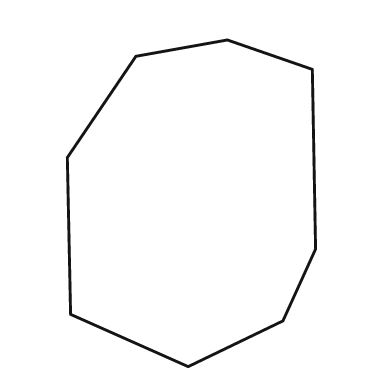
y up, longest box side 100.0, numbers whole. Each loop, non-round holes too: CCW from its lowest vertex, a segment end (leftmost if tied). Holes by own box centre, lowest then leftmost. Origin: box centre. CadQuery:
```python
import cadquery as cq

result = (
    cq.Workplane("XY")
    .moveTo(-1.0, -50.0)
    .lineTo(28.0, -36.0)
    .lineTo(38.0, -14.0)
    .lineTo(37.0, 41.0)
    .lineTo(11.0, 50.0)
    .lineTo(-17.0, 45.0)
    .lineTo(-38.0, 14.0)
    .lineTo(-37.0, -34.0)
    .close()
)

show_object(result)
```